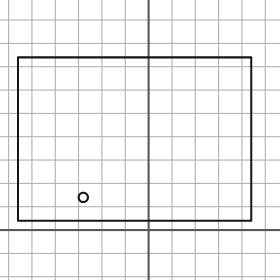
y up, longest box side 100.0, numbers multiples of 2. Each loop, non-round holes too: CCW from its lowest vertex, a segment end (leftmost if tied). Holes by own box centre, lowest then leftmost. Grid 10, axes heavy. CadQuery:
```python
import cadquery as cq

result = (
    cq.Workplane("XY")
    .moveTo(-56.0, 4.0)
    .lineTo(44.0, 4.0)
    .lineTo(44.0, 74.0)
    .lineTo(-56.0, 74.0)
    .close()
    .moveTo(-28.0, 14.0)
    .circle(2.0)
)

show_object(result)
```